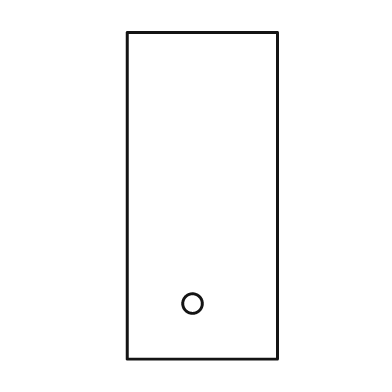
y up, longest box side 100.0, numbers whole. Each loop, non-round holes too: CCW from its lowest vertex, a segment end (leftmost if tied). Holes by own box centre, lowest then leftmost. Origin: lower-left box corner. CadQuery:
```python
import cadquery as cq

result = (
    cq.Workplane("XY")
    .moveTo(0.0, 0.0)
    .lineTo(46.0, 0.0)
    .lineTo(46.0, 100.0)
    .lineTo(0.0, 100.0)
    .close()
    .moveTo(20.0, 17.0)
    .circle(3.0)
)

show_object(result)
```